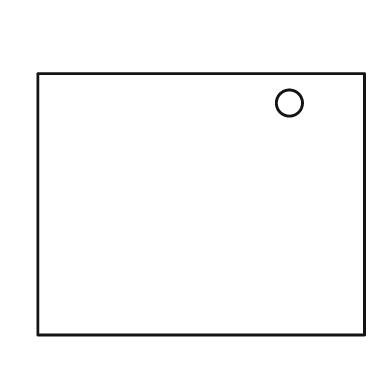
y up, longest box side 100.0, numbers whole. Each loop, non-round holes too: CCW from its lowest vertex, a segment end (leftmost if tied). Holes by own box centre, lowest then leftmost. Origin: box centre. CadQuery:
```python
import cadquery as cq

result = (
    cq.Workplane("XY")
    .moveTo(-50.0, -40.0)
    .lineTo(50.0, -40.0)
    .lineTo(50.0, 40.0)
    .lineTo(-50.0, 40.0)
    .close()
    .moveTo(27.0, 31.0)
    .circle(4.0)
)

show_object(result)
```